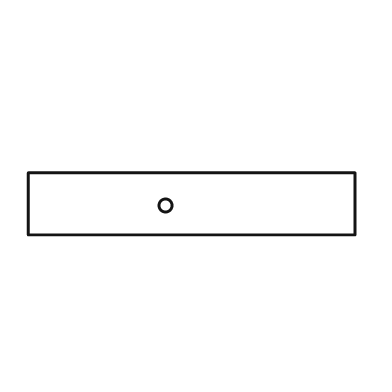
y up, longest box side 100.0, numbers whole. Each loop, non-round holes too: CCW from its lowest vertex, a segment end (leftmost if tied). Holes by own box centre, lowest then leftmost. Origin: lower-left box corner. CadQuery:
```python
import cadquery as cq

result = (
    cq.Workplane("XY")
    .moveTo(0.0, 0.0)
    .lineTo(100.0, 0.0)
    .lineTo(100.0, 19.0)
    .lineTo(0.0, 19.0)
    .close()
    .moveTo(42.0, 9.0)
    .circle(2.0)
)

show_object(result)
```